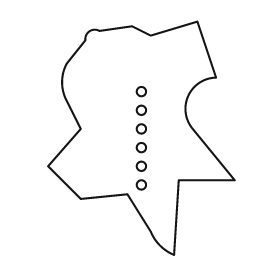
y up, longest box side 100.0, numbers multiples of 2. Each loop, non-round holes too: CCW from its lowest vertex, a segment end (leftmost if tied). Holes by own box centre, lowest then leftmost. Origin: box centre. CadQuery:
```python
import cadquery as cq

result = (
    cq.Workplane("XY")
    .moveTo(14.0, -50.0)
    .lineTo(16.0, -18.0)
    .lineTo(40.0, -18.0)
    .lineTo(22.0, 4.0)
    .threePointArc((20.0, 18.0), (32.0, 26.0))
    .lineTo(24.0, 50.0)
    .lineTo(4.0, 44.0)
    .lineTo(-4.0, 48.0)
    .lineTo(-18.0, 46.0)
    .threePointArc((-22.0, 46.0), (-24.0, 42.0))
    .lineTo(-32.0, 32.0)
    .threePointArc((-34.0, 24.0), (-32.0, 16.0))
    .lineTo(-26.0, 4.0)
    .lineTo(-40.0, -12.0)
    .lineTo(-26.0, -26.0)
    .lineTo(-6.0, -24.0)
    .lineTo(4.0, -40.0)
    .threePointArc((8.0, -46.0), (14.0, -50.0))
    .close()
    .moveTo(0.0, -20.0)
    .circle(2.0)
    .moveTo(0.0, -12.0)
    .circle(2.0)
    .moveTo(0.0, -4.0)
    .circle(2.0)
    .moveTo(0.0, 4.0)
    .circle(2.0)
    .moveTo(0.0, 12.0)
    .circle(2.0)
    .moveTo(0.0, 20.0)
    .circle(2.0)
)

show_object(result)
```